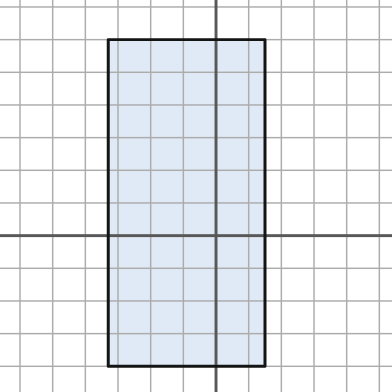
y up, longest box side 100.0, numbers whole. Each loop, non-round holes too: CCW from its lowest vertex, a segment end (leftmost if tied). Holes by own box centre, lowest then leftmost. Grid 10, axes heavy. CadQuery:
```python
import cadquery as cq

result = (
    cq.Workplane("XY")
    .moveTo(-33.0, -40.0)
    .lineTo(15.0, -40.0)
    .lineTo(15.0, 60.0)
    .lineTo(-33.0, 60.0)
    .close()
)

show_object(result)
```